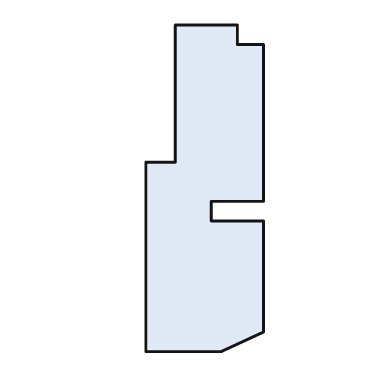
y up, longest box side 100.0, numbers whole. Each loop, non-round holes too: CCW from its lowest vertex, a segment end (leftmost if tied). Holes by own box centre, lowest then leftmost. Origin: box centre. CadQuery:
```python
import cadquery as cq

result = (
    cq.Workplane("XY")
    .moveTo(-18.0, -50.0)
    .lineTo(5.0, -50.0)
    .lineTo(18.0, -44.0)
    .lineTo(18.0, -10.0)
    .lineTo(2.0, -10.0)
    .lineTo(2.0, -4.0)
    .lineTo(18.0, -4.0)
    .lineTo(18.0, 44.0)
    .lineTo(10.0, 44.0)
    .lineTo(10.0, 50.0)
    .lineTo(-9.0, 50.0)
    .lineTo(-9.0, 8.0)
    .lineTo(-18.0, 8.0)
    .close()
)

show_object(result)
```